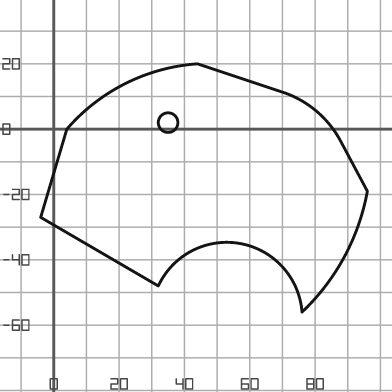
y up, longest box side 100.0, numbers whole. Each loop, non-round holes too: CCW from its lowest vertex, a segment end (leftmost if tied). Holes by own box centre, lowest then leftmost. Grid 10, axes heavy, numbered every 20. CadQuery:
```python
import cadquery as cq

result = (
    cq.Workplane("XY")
    .moveTo(76.0, -56.0)
    .threePointArc((89.0, -39.0), (96.0, -19.0))
    .lineTo(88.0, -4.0)
    .threePointArc((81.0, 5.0), (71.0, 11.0))
    .lineTo(44.0, 20.0)
    .threePointArc((22.0, 14.0), (4.0, 0.0))
    .lineTo(-4.0, -27.0)
    .lineTo(32.0, -48.0)
    .threePointArc((57.0, -35.0), (76.0, -56.0))
    .close()
    .moveTo(35.0, 2.0)
    .circle(3.0)
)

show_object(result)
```